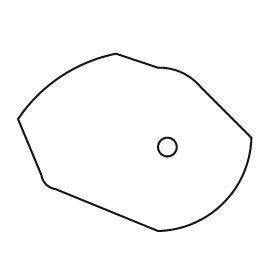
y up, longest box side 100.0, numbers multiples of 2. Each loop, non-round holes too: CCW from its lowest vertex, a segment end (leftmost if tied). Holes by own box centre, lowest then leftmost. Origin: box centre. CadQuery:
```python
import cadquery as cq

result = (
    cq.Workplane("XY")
    .moveTo(10.0, -38.0)
    .threePointArc((38.0, -26.0), (50.0, 2.0))
    .lineTo(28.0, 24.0)
    .threePointArc((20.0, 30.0), (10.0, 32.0))
    .lineTo(-8.0, 38.0)
    .threePointArc((-32.0, 28.0), (-50.0, 10.0))
    .lineTo(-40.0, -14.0)
    .threePointArc((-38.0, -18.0), (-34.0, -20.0))
    .close()
    .moveTo(14.0, -2.0)
    .circle(4.0)
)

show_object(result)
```